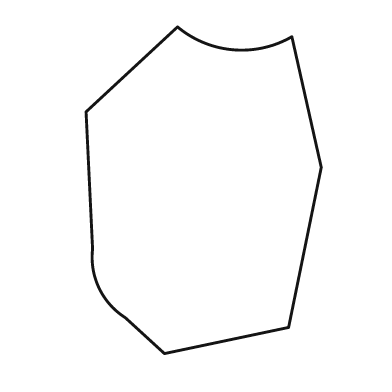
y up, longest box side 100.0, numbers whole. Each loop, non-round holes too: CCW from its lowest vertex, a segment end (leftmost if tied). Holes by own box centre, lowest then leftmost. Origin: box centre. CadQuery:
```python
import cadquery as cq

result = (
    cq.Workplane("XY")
    .moveTo(-12.0, -50.0)
    .lineTo(26.0, -42.0)
    .lineTo(36.0, 7.0)
    .lineTo(27.0, 47.0)
    .threePointArc((9.0, 43.0), (-8.0, 50.0))
    .lineTo(-36.0, 24.0)
    .lineTo(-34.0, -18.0)
    .threePointArc((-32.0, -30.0), (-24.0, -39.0))
    .close()
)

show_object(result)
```